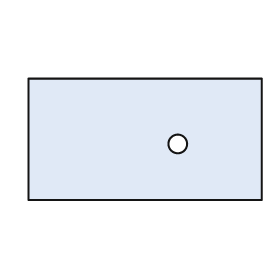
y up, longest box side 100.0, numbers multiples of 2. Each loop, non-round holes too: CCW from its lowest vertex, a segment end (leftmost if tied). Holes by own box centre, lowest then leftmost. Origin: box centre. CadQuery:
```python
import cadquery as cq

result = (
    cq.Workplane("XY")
    .moveTo(-50.0, -26.0)
    .lineTo(50.0, -26.0)
    .lineTo(50.0, 26.0)
    .lineTo(-50.0, 26.0)
    .close()
    .moveTo(14.0, -2.0)
    .circle(4.0)
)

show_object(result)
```